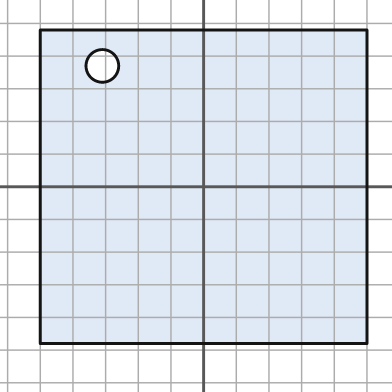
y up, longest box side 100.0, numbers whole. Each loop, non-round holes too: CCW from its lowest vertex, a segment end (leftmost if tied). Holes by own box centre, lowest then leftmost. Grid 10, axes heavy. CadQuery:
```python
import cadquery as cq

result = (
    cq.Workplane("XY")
    .moveTo(-50.0, -48.0)
    .lineTo(50.0, -48.0)
    .lineTo(50.0, 48.0)
    .lineTo(-50.0, 48.0)
    .close()
    .moveTo(-31.0, 37.0)
    .circle(5.0)
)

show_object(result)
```